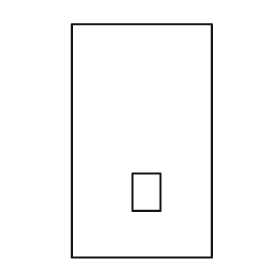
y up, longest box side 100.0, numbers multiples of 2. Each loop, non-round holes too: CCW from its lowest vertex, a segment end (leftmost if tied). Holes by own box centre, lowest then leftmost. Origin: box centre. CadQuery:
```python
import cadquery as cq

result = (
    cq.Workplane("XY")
    .moveTo(-30.0, -50.0)
    .lineTo(30.0, -50.0)
    .lineTo(30.0, 50.0)
    .lineTo(-30.0, 50.0)
    .close()
    .moveTo(-4.0, -30.0)
    .lineTo(8.0, -30.0)
    .lineTo(8.0, -14.0)
    .lineTo(-4.0, -14.0)
    .close()
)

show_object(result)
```